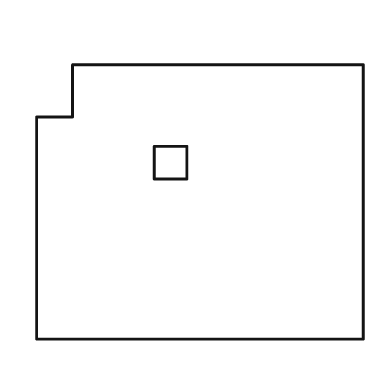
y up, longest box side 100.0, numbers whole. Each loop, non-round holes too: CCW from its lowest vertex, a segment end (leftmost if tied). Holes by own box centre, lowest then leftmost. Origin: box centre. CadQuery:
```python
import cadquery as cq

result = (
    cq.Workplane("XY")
    .moveTo(-50.0, -42.0)
    .lineTo(50.0, -42.0)
    .lineTo(50.0, 42.0)
    .lineTo(-39.0, 42.0)
    .lineTo(-39.0, 26.0)
    .lineTo(-50.0, 26.0)
    .close()
    .moveTo(-14.0, 7.0)
    .lineTo(-4.0, 7.0)
    .lineTo(-4.0, 17.0)
    .lineTo(-14.0, 17.0)
    .close()
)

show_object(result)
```